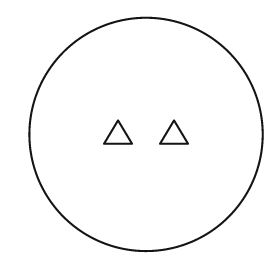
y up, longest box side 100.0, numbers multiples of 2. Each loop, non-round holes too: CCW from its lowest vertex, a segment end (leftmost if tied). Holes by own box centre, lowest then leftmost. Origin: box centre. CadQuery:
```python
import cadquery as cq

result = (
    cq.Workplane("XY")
    .moveTo(0.0, 0.0)
    .circle(50.0)
    .moveTo(-18.0, -4.0)
    .lineTo(-6.0, -4.0)
    .lineTo(-12.0, 6.0)
    .close()
    .moveTo(6.0, -4.0)
    .lineTo(18.0, -4.0)
    .lineTo(12.0, 6.0)
    .close()
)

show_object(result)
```